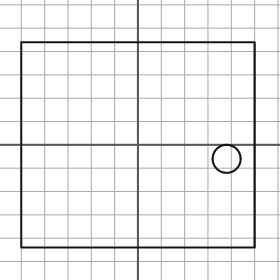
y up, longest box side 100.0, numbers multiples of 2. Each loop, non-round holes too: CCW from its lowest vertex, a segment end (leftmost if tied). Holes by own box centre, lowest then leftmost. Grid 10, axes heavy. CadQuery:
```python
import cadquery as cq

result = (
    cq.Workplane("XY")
    .moveTo(-50.0, -44.0)
    .lineTo(50.0, -44.0)
    .lineTo(50.0, 44.0)
    .lineTo(-50.0, 44.0)
    .close()
    .moveTo(38.0, -6.0)
    .circle(6.0)
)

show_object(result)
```